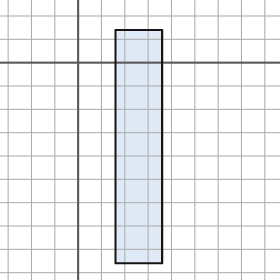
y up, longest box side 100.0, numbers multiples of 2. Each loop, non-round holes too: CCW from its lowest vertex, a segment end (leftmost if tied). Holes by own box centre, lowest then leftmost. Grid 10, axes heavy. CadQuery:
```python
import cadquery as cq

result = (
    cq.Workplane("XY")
    .moveTo(16.0, -86.0)
    .lineTo(36.0, -86.0)
    .lineTo(36.0, 14.0)
    .lineTo(16.0, 14.0)
    .close()
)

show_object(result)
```